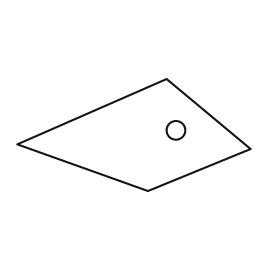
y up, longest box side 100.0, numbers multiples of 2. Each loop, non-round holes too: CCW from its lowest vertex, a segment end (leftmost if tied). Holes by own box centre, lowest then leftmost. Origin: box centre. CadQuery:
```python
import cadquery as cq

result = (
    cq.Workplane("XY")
    .moveTo(6.0, -24.0)
    .lineTo(50.0, -6.0)
    .lineTo(14.0, 24.0)
    .lineTo(-50.0, -4.0)
    .close()
    .moveTo(18.0, 2.0)
    .circle(4.0)
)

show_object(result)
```